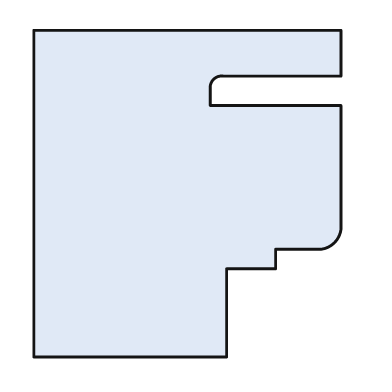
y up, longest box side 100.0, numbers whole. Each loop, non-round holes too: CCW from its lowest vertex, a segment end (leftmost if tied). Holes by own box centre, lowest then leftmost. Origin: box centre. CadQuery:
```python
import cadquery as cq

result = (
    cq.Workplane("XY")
    .moveTo(-47.0, -50.0)
    .lineTo(12.0, -50.0)
    .lineTo(12.0, -23.0)
    .lineTo(27.0, -23.0)
    .lineTo(27.0, -17.0)
    .lineTo(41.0, -17.0)
    .threePointArc((45.0, -15.0), (47.0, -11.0))
    .lineTo(47.0, 27.0)
    .lineTo(7.0, 27.0)
    .lineTo(7.0, 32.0)
    .threePointArc((8.0, 35.0), (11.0, 36.0))
    .lineTo(47.0, 36.0)
    .lineTo(47.0, 50.0)
    .lineTo(-47.0, 50.0)
    .close()
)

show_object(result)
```